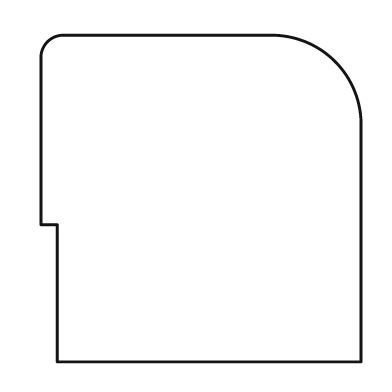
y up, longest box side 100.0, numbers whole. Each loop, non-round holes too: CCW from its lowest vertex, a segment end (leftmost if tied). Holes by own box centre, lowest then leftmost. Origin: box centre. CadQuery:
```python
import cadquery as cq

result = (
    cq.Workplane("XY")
    .moveTo(-44.0, -50.0)
    .lineTo(49.0, -50.0)
    .lineTo(49.0, 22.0)
    .threePointArc((41.0, 42.0), (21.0, 50.0))
    .lineTo(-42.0, 50.0)
    .threePointArc((-47.0, 48.0), (-49.0, 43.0))
    .lineTo(-49.0, -8.0)
    .lineTo(-44.0, -8.0)
    .close()
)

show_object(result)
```